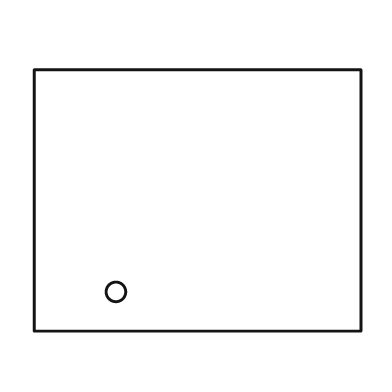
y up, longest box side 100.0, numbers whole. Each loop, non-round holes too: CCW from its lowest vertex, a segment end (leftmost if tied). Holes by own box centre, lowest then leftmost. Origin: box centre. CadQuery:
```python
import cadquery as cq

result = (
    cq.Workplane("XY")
    .moveTo(-50.0, -40.0)
    .lineTo(50.0, -40.0)
    .lineTo(50.0, 40.0)
    .lineTo(-50.0, 40.0)
    .close()
    .moveTo(-25.0, -28.0)
    .circle(3.0)
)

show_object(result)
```